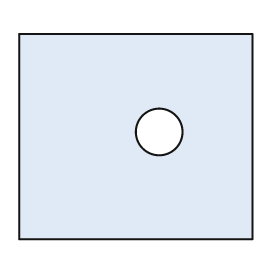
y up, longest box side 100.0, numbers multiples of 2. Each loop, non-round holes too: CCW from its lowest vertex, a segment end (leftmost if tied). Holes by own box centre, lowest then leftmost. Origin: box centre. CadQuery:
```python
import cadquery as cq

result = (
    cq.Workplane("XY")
    .moveTo(-50.0, -44.0)
    .lineTo(50.0, -44.0)
    .lineTo(50.0, 44.0)
    .lineTo(-50.0, 44.0)
    .close()
    .moveTo(10.0, 2.0)
    .circle(10.0)
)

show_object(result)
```